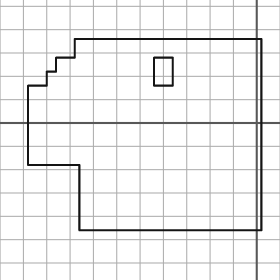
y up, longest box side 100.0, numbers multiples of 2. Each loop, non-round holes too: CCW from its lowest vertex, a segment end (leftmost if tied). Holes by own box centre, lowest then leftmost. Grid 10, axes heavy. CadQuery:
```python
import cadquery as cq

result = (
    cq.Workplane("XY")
    .moveTo(-76.0, -46.0)
    .lineTo(2.0, -46.0)
    .lineTo(2.0, 36.0)
    .lineTo(-78.0, 36.0)
    .lineTo(-78.0, 28.0)
    .lineTo(-86.0, 28.0)
    .lineTo(-86.0, 22.0)
    .lineTo(-90.0, 22.0)
    .lineTo(-90.0, 16.0)
    .lineTo(-98.0, 16.0)
    .lineTo(-98.0, -18.0)
    .lineTo(-76.0, -18.0)
    .close()
    .moveTo(-44.0, 16.0)
    .lineTo(-36.0, 16.0)
    .lineTo(-36.0, 28.0)
    .lineTo(-44.0, 28.0)
    .close()
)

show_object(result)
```